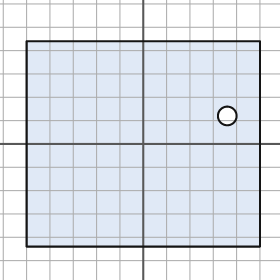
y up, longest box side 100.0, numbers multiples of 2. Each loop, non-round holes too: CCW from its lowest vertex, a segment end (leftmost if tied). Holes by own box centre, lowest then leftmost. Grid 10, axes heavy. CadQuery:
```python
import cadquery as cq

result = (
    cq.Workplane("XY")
    .moveTo(-50.0, -44.0)
    .lineTo(50.0, -44.0)
    .lineTo(50.0, 44.0)
    .lineTo(-50.0, 44.0)
    .close()
    .moveTo(36.0, 12.0)
    .circle(4.0)
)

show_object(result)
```